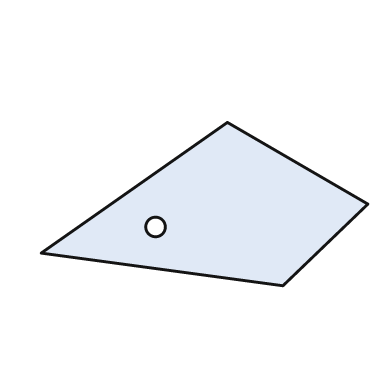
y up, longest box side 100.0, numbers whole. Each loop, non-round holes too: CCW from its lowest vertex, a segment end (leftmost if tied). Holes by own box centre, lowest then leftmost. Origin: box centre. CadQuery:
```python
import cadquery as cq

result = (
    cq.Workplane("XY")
    .moveTo(24.0, -25.0)
    .lineTo(50.0, 0.0)
    .lineTo(7.0, 25.0)
    .lineTo(-50.0, -15.0)
    .close()
    .moveTo(-15.0, -7.0)
    .circle(3.0)
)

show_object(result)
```